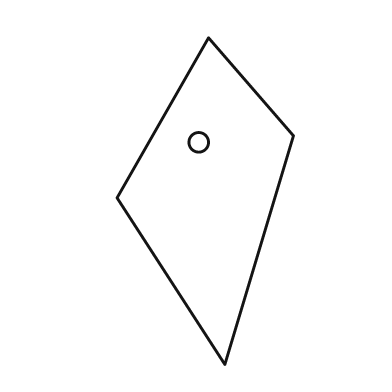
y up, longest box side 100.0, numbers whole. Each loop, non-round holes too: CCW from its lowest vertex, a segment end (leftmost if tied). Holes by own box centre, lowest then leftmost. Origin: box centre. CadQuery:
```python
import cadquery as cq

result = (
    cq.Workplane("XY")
    .moveTo(6.0, -50.0)
    .lineTo(27.0, 20.0)
    .lineTo(1.0, 50.0)
    .lineTo(-27.0, 1.0)
    .close()
    .moveTo(-2.0, 18.0)
    .circle(3.0)
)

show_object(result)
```